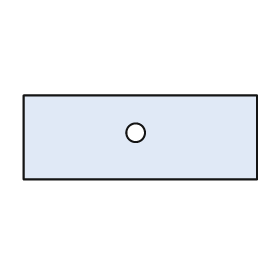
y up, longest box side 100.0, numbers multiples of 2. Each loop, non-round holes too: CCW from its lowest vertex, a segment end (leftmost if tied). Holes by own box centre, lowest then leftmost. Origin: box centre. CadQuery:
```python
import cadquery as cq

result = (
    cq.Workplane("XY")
    .moveTo(-50.0, -18.0)
    .lineTo(50.0, -18.0)
    .lineTo(50.0, 18.0)
    .lineTo(-50.0, 18.0)
    .close()
    .moveTo(-2.0, 2.0)
    .circle(4.0)
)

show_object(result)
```